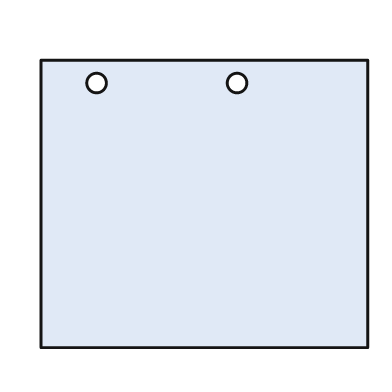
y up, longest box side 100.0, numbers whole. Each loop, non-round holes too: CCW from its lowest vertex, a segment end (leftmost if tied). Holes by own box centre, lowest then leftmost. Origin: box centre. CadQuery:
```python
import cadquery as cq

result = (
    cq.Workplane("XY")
    .moveTo(-50.0, -44.0)
    .lineTo(50.0, -44.0)
    .lineTo(50.0, 44.0)
    .lineTo(-50.0, 44.0)
    .close()
    .moveTo(-33.0, 37.0)
    .circle(3.0)
    .moveTo(10.0, 37.0)
    .circle(3.0)
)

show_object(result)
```